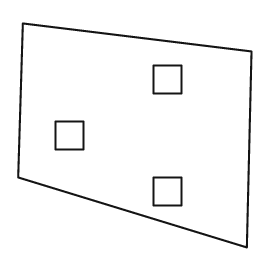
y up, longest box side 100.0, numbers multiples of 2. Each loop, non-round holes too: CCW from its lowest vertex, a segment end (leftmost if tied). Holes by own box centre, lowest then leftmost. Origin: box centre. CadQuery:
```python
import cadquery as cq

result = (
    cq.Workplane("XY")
    .moveTo(48.0, -48.0)
    .lineTo(50.0, 36.0)
    .lineTo(-48.0, 48.0)
    .lineTo(-50.0, -18.0)
    .close()
    .moveTo(8.0, -30.0)
    .lineTo(20.0, -30.0)
    .lineTo(20.0, -18.0)
    .lineTo(8.0, -18.0)
    .close()
    .moveTo(-34.0, -6.0)
    .lineTo(-22.0, -6.0)
    .lineTo(-22.0, 6.0)
    .lineTo(-34.0, 6.0)
    .close()
    .moveTo(8.0, 18.0)
    .lineTo(20.0, 18.0)
    .lineTo(20.0, 30.0)
    .lineTo(8.0, 30.0)
    .close()
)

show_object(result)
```